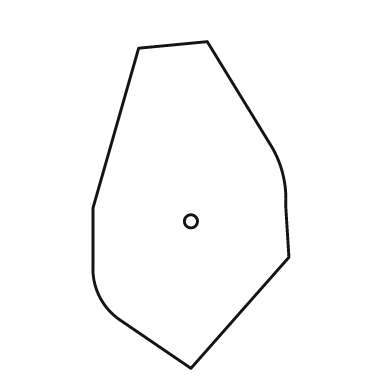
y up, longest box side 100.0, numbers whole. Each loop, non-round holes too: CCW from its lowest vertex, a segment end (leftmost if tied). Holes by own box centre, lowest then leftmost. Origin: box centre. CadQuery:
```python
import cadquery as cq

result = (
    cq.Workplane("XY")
    .moveTo(0.0, -50.0)
    .lineTo(30.0, -16.0)
    .lineTo(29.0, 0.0)
    .threePointArc((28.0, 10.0), (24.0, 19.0))
    .lineTo(5.0, 50.0)
    .lineTo(-16.0, 48.0)
    .lineTo(-30.0, -1.0)
    .lineTo(-30.0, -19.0)
    .threePointArc((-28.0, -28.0), (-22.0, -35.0))
    .close()
    .moveTo(0.0, -5.0)
    .circle(2.0)
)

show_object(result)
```